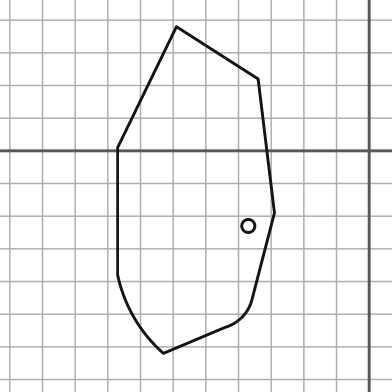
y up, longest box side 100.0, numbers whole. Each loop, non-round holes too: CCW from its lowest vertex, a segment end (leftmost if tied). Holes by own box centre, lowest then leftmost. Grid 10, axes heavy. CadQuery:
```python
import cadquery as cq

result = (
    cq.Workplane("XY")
    .moveTo(-63.0, -62.0)
    .lineTo(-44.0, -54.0)
    .threePointArc((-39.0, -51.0), (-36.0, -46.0))
    .lineTo(-29.0, -19.0)
    .lineTo(-34.0, 22.0)
    .lineTo(-59.0, 38.0)
    .lineTo(-77.0, 1.0)
    .lineTo(-77.0, -38.0)
    .threePointArc((-72.0, -51.0), (-63.0, -62.0))
    .close()
    .moveTo(-37.0, -23.0)
    .circle(2.0)
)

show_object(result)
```